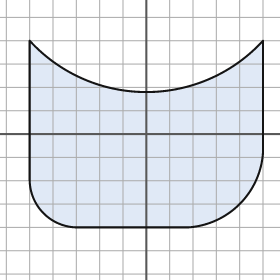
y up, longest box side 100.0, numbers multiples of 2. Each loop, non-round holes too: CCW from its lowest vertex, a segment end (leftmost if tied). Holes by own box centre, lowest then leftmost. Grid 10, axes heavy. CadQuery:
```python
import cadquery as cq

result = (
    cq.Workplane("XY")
    .moveTo(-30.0, -40.0)
    .lineTo(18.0, -40.0)
    .threePointArc((40.0, -30.0), (50.0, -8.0))
    .lineTo(50.0, 40.0)
    .threePointArc((0.0, 18.0), (-50.0, 40.0))
    .lineTo(-50.0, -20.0)
    .threePointArc((-44.0, -34.0), (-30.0, -40.0))
    .close()
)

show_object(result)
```